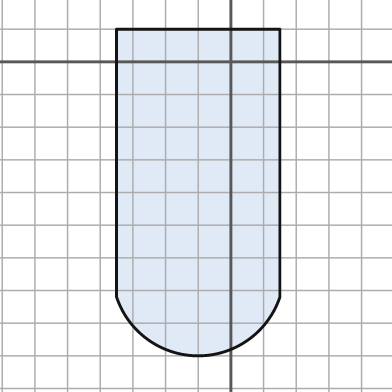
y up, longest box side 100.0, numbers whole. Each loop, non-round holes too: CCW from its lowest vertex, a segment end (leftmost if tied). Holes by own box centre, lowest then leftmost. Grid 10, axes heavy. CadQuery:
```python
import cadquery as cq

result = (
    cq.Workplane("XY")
    .moveTo(-35.0, -72.0)
    .threePointArc((-10.0, -90.0), (15.0, -72.0))
    .lineTo(15.0, 10.0)
    .lineTo(-35.0, 10.0)
    .close()
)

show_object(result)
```